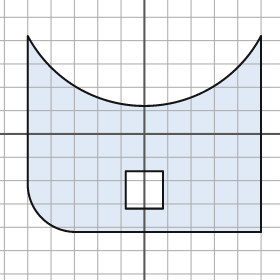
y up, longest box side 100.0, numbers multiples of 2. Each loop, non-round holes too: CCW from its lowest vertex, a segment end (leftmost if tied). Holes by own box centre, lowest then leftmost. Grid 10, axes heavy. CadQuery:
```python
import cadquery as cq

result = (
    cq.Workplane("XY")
    .moveTo(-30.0, -42.0)
    .lineTo(50.0, -42.0)
    .lineTo(50.0, 42.0)
    .threePointArc((0.0, 12.0), (-50.0, 42.0))
    .lineTo(-50.0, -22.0)
    .threePointArc((-44.0, -36.0), (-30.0, -42.0))
    .close()
    .moveTo(-8.0, -32.0)
    .lineTo(8.0, -32.0)
    .lineTo(8.0, -16.0)
    .lineTo(-8.0, -16.0)
    .close()
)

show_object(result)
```